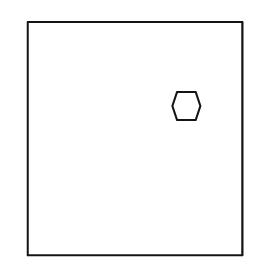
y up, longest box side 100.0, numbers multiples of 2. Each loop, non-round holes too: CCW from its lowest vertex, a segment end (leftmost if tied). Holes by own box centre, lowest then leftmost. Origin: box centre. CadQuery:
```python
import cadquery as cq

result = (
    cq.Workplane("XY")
    .moveTo(-46.0, -50.0)
    .lineTo(46.0, -50.0)
    .lineTo(46.0, 50.0)
    .lineTo(-46.0, 50.0)
    .close()
    .moveTo(18.0, 8.0)
    .lineTo(26.0, 8.0)
    .lineTo(28.0, 14.0)
    .lineTo(26.0, 20.0)
    .lineTo(18.0, 20.0)
    .lineTo(16.0, 14.0)
    .close()
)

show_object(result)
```